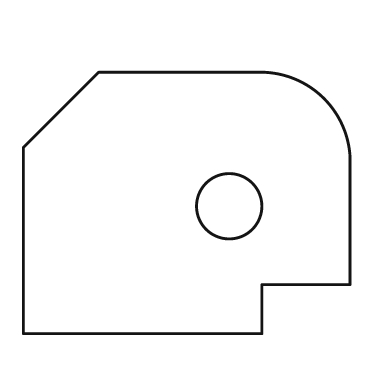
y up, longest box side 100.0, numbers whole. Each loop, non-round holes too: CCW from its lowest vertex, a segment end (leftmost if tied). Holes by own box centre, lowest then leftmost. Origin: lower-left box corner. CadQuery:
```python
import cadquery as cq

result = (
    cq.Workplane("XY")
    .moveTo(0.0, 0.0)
    .lineTo(73.0, 0.0)
    .lineTo(73.0, 15.0)
    .lineTo(100.0, 15.0)
    .lineTo(100.0, 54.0)
    .threePointArc((92.0, 72.0), (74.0, 80.0))
    .lineTo(23.0, 80.0)
    .lineTo(0.0, 57.0)
    .close()
    .moveTo(63.0, 39.0)
    .circle(10.0)
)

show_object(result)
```